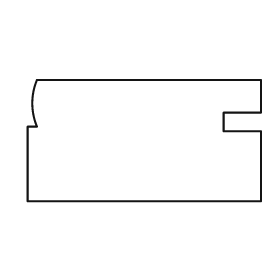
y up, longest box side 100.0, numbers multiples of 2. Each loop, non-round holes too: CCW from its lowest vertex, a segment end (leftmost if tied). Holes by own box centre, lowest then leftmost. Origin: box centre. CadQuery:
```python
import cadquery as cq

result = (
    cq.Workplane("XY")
    .moveTo(-50.0, -26.0)
    .lineTo(50.0, -26.0)
    .lineTo(50.0, 4.0)
    .lineTo(34.0, 4.0)
    .lineTo(34.0, 12.0)
    .lineTo(50.0, 12.0)
    .lineTo(50.0, 26.0)
    .lineTo(-46.0, 26.0)
    .threePointArc((-48.0, 16.0), (-46.0, 6.0))
    .lineTo(-50.0, 6.0)
    .close()
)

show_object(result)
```